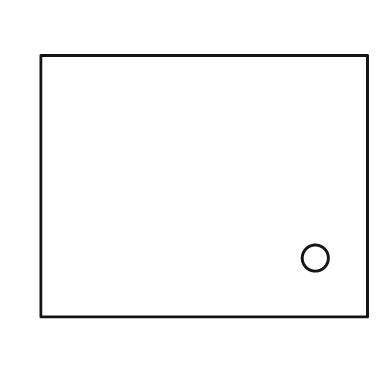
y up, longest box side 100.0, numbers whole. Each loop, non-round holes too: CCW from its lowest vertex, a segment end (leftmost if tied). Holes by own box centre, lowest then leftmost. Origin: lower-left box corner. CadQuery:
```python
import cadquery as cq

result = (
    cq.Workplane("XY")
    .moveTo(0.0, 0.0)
    .lineTo(100.0, 0.0)
    .lineTo(100.0, 80.0)
    .lineTo(0.0, 80.0)
    .close()
    .moveTo(84.0, 18.0)
    .circle(4.0)
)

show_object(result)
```